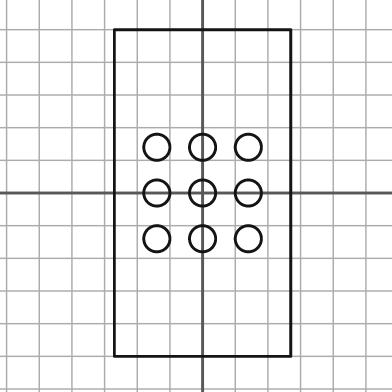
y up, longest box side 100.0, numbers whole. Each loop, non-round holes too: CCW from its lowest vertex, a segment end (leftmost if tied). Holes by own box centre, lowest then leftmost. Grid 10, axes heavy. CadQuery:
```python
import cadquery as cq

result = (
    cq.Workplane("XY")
    .moveTo(-27.0, -50.0)
    .lineTo(27.0, -50.0)
    .lineTo(27.0, 50.0)
    .lineTo(-27.0, 50.0)
    .close()
    .moveTo(-14.0, -14.0)
    .circle(4.0)
    .moveTo(0.0, -14.0)
    .circle(4.0)
    .moveTo(14.0, -14.0)
    .circle(4.0)
    .moveTo(-14.0, 0.0)
    .circle(4.0)
    .moveTo(0.0, 0.0)
    .circle(4.0)
    .moveTo(14.0, 0.0)
    .circle(4.0)
    .moveTo(-14.0, 14.0)
    .circle(4.0)
    .moveTo(0.0, 14.0)
    .circle(4.0)
    .moveTo(14.0, 14.0)
    .circle(4.0)
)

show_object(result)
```